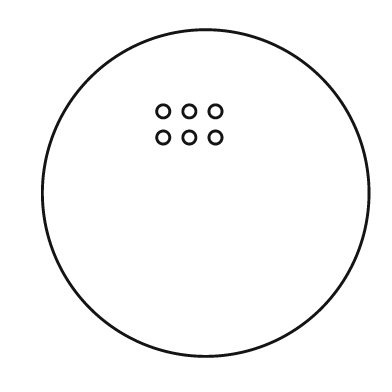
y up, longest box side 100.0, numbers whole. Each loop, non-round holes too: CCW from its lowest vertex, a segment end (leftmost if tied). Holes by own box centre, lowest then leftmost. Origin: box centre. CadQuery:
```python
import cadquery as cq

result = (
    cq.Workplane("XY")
    .moveTo(0.0, 0.0)
    .circle(50.0)
    .moveTo(-13.0, 17.0)
    .circle(2.0)
    .moveTo(-5.0, 17.0)
    .circle(2.0)
    .moveTo(3.0, 17.0)
    .circle(2.0)
    .moveTo(-13.0, 25.0)
    .circle(2.0)
    .moveTo(-5.0, 25.0)
    .circle(2.0)
    .moveTo(3.0, 25.0)
    .circle(2.0)
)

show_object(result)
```